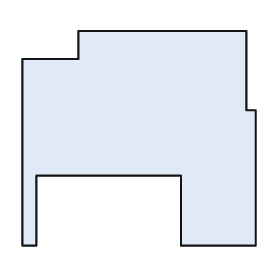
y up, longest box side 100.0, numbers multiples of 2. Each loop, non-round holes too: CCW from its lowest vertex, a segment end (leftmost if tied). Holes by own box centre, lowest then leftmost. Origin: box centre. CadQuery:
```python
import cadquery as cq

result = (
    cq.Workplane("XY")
    .moveTo(-50.0, -46.0)
    .lineTo(-44.0, -46.0)
    .lineTo(-44.0, -16.0)
    .lineTo(18.0, -16.0)
    .lineTo(18.0, -46.0)
    .lineTo(50.0, -46.0)
    .lineTo(50.0, 12.0)
    .lineTo(46.0, 12.0)
    .lineTo(46.0, 46.0)
    .lineTo(-26.0, 46.0)
    .lineTo(-26.0, 34.0)
    .lineTo(-50.0, 34.0)
    .close()
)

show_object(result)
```